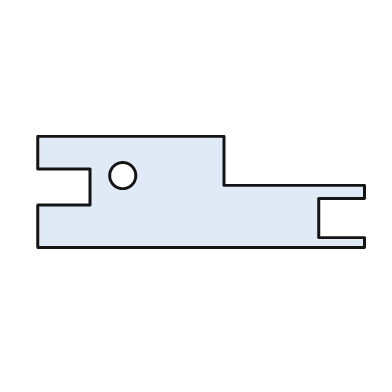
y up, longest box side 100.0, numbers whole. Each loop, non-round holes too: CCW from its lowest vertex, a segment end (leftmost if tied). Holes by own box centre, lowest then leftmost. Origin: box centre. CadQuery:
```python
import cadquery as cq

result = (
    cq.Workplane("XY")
    .moveTo(-50.0, -17.0)
    .lineTo(50.0, -17.0)
    .lineTo(50.0, -14.0)
    .lineTo(36.0, -14.0)
    .lineTo(36.0, -2.0)
    .lineTo(50.0, -2.0)
    .lineTo(50.0, 2.0)
    .lineTo(7.0, 2.0)
    .lineTo(7.0, 17.0)
    .lineTo(-50.0, 17.0)
    .lineTo(-50.0, 7.0)
    .lineTo(-34.0, 7.0)
    .lineTo(-34.0, -4.0)
    .lineTo(-50.0, -4.0)
    .close()
    .moveTo(-24.0, 5.0)
    .circle(4.0)
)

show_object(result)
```